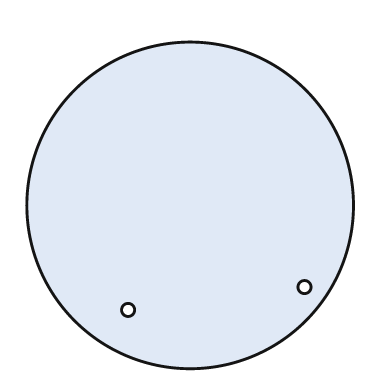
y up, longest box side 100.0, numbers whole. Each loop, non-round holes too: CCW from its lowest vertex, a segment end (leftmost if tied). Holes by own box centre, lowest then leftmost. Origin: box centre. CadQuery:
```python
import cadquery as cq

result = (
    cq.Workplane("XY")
    .moveTo(0.0, 0.0)
    .circle(50.0)
    .moveTo(-19.0, -32.0)
    .circle(2.0)
    .moveTo(35.0, -25.0)
    .circle(2.0)
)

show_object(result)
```